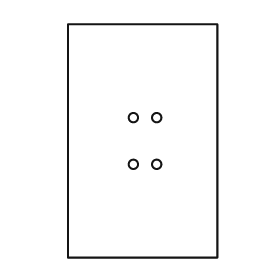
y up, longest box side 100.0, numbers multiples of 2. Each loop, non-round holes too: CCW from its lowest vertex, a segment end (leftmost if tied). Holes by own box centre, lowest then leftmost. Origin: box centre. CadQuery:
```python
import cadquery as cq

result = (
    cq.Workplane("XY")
    .moveTo(-32.0, -50.0)
    .lineTo(32.0, -50.0)
    .lineTo(32.0, 50.0)
    .lineTo(-32.0, 50.0)
    .close()
    .moveTo(-4.0, -10.0)
    .circle(2.0)
    .moveTo(6.0, -10.0)
    .circle(2.0)
    .moveTo(-4.0, 10.0)
    .circle(2.0)
    .moveTo(6.0, 10.0)
    .circle(2.0)
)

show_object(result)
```